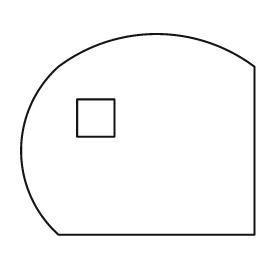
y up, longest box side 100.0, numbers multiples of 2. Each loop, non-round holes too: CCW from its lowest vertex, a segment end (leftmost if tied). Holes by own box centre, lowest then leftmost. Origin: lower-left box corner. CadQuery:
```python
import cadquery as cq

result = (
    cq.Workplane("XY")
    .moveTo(16.0, 0.0)
    .lineTo(100.0, 0.0)
    .lineTo(100.0, 72.0)
    .threePointArc((58.0, 86.0), (16.0, 72.0))
    .threePointArc((0.0, 36.0), (16.0, 0.0))
    .close()
    .moveTo(24.0, 42.0)
    .lineTo(40.0, 42.0)
    .lineTo(40.0, 58.0)
    .lineTo(24.0, 58.0)
    .close()
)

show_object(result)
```